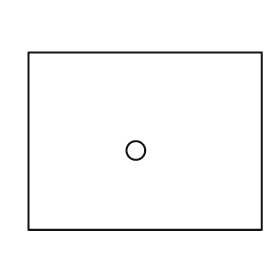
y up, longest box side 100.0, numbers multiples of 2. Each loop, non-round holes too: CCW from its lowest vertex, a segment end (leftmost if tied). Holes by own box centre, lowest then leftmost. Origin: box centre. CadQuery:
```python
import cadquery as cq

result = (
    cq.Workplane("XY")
    .moveTo(-50.0, -38.0)
    .lineTo(50.0, -38.0)
    .lineTo(50.0, 38.0)
    .lineTo(-50.0, 38.0)
    .close()
    .moveTo(-4.0, -4.0)
    .circle(4.0)
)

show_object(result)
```